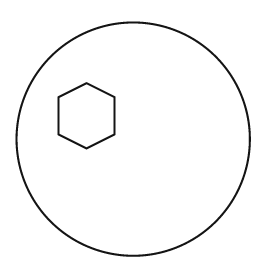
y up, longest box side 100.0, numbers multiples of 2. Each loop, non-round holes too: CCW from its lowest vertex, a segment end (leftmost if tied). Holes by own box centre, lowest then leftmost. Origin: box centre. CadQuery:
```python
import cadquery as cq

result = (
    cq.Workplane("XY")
    .moveTo(0.0, 0.0)
    .circle(50.0)
    .moveTo(-20.0, -4.0)
    .lineTo(-8.0, 2.0)
    .lineTo(-8.0, 18.0)
    .lineTo(-20.0, 24.0)
    .lineTo(-32.0, 18.0)
    .lineTo(-32.0, 2.0)
    .close()
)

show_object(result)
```